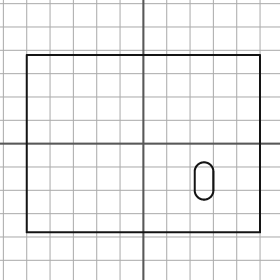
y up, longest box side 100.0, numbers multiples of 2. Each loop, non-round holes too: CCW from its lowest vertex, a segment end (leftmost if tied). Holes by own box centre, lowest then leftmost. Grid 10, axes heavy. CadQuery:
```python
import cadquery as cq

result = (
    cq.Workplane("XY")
    .moveTo(-50.0, -38.0)
    .lineTo(50.0, -38.0)
    .lineTo(50.0, 38.0)
    .lineTo(-50.0, 38.0)
    .close()
    .moveTo(22.0, -20.0)
    .threePointArc((26.0, -24.0), (30.0, -20.0))
    .lineTo(30.0, -12.0)
    .threePointArc((26.0, -8.0), (22.0, -12.0))
    .close()
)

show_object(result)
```